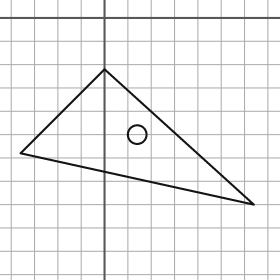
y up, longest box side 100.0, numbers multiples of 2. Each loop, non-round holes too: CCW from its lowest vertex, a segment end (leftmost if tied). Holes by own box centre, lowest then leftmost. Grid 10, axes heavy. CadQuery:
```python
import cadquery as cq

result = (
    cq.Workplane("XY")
    .moveTo(64.0, -80.0)
    .lineTo(0.0, -22.0)
    .lineTo(-36.0, -58.0)
    .close()
    .moveTo(14.0, -50.0)
    .circle(4.0)
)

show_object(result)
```